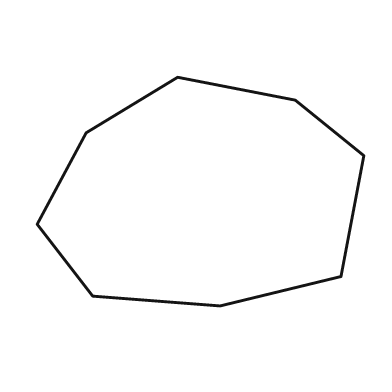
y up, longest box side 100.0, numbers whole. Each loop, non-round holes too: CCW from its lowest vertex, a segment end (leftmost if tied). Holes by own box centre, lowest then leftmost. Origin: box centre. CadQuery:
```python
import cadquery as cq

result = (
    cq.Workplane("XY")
    .moveTo(6.0, -35.0)
    .lineTo(43.0, -26.0)
    .lineTo(50.0, 11.0)
    .lineTo(29.0, 28.0)
    .lineTo(-7.0, 35.0)
    .lineTo(-35.0, 18.0)
    .lineTo(-50.0, -10.0)
    .lineTo(-33.0, -32.0)
    .close()
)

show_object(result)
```